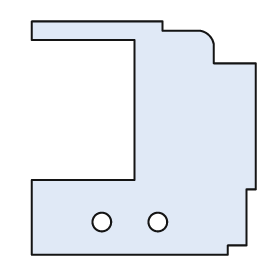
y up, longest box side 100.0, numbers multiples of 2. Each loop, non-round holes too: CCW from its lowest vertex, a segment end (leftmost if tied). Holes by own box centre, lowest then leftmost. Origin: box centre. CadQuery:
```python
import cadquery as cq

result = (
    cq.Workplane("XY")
    .moveTo(-48.0, -50.0)
    .lineTo(36.0, -50.0)
    .lineTo(36.0, -46.0)
    .lineTo(44.0, -46.0)
    .lineTo(44.0, -22.0)
    .lineTo(48.0, -22.0)
    .lineTo(48.0, 32.0)
    .lineTo(30.0, 32.0)
    .lineTo(30.0, 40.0)
    .threePointArc((28.0, 44.0), (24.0, 46.0))
    .lineTo(8.0, 46.0)
    .lineTo(8.0, 50.0)
    .lineTo(-48.0, 50.0)
    .lineTo(-48.0, 42.0)
    .lineTo(-4.0, 42.0)
    .lineTo(-4.0, -18.0)
    .lineTo(-48.0, -18.0)
    .close()
    .moveTo(-18.0, -36.0)
    .circle(4.0)
    .moveTo(6.0, -36.0)
    .circle(4.0)
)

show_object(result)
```